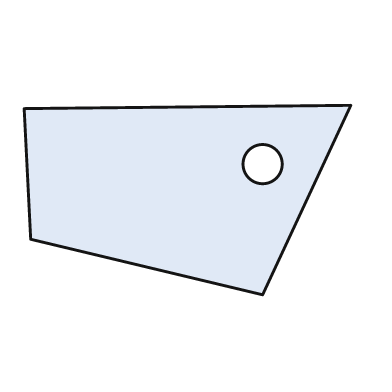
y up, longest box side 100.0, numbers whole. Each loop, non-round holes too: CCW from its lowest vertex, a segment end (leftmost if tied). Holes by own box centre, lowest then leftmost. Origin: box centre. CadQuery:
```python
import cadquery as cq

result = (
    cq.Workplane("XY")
    .moveTo(23.0, -29.0)
    .lineTo(50.0, 29.0)
    .lineTo(-50.0, 28.0)
    .lineTo(-48.0, -12.0)
    .close()
    .moveTo(23.0, 11.0)
    .circle(6.0)
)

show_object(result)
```